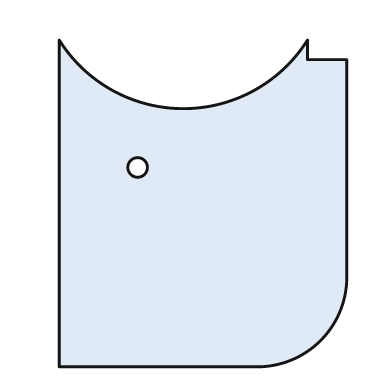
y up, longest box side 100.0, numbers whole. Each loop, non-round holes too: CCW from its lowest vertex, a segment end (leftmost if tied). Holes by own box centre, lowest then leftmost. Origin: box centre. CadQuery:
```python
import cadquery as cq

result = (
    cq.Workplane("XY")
    .moveTo(-44.0, -50.0)
    .lineTo(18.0, -50.0)
    .threePointArc((36.0, -42.0), (44.0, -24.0))
    .lineTo(44.0, 44.0)
    .lineTo(32.0, 44.0)
    .lineTo(32.0, 50.0)
    .threePointArc((-6.0, 29.0), (-44.0, 50.0))
    .close()
    .moveTo(-20.0, 11.0)
    .circle(3.0)
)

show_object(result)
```